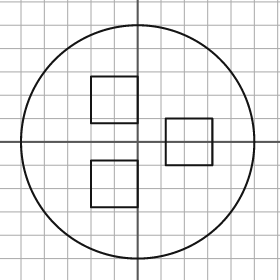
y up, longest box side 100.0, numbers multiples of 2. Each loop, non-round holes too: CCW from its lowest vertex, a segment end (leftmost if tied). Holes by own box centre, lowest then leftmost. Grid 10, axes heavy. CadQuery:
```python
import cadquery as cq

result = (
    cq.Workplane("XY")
    .moveTo(0.0, 0.0)
    .circle(50.0)
    .moveTo(-20.0, -28.0)
    .lineTo(0.0, -28.0)
    .lineTo(0.0, -8.0)
    .lineTo(-20.0, -8.0)
    .close()
    .moveTo(12.0, -10.0)
    .lineTo(32.0, -10.0)
    .lineTo(32.0, 10.0)
    .lineTo(12.0, 10.0)
    .close()
    .moveTo(-20.0, 8.0)
    .lineTo(0.0, 8.0)
    .lineTo(0.0, 28.0)
    .lineTo(-20.0, 28.0)
    .close()
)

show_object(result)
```